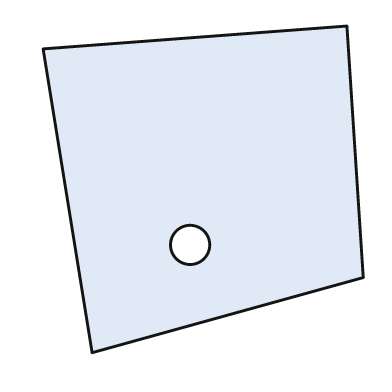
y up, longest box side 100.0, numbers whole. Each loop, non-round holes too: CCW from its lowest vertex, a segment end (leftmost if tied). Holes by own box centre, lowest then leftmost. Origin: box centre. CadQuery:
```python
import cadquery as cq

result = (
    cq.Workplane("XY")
    .moveTo(-34.0, -50.0)
    .lineTo(49.0, -27.0)
    .lineTo(44.0, 50.0)
    .lineTo(-49.0, 43.0)
    .close()
    .moveTo(-4.0, -17.0)
    .circle(6.0)
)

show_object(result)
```